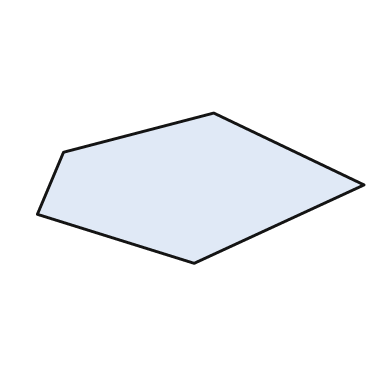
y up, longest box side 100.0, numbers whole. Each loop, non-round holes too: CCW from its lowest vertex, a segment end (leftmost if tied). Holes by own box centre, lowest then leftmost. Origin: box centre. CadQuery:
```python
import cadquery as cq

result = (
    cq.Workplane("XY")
    .moveTo(-2.0, -23.0)
    .lineTo(50.0, 1.0)
    .lineTo(4.0, 23.0)
    .lineTo(-42.0, 11.0)
    .lineTo(-50.0, -8.0)
    .close()
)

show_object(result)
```